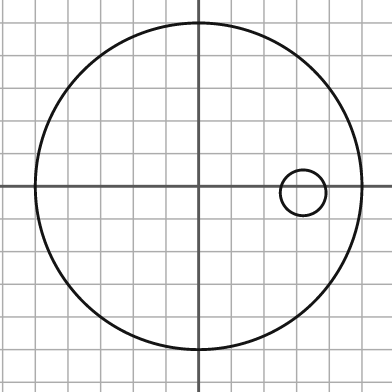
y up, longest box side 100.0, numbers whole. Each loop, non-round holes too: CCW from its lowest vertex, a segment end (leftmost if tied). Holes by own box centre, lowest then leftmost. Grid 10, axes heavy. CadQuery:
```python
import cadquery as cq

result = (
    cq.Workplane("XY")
    .moveTo(0.0, 0.0)
    .circle(50.0)
    .moveTo(32.0, -2.0)
    .circle(7.0)
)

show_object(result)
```